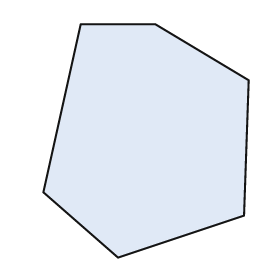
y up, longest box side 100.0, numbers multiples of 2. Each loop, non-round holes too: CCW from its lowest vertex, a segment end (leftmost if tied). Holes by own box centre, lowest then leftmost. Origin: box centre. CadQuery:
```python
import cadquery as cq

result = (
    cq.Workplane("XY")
    .moveTo(-12.0, -50.0)
    .lineTo(42.0, -32.0)
    .lineTo(44.0, 26.0)
    .lineTo(4.0, 50.0)
    .lineTo(-28.0, 50.0)
    .lineTo(-44.0, -22.0)
    .close()
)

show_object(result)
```